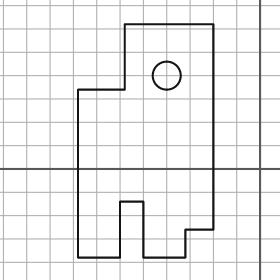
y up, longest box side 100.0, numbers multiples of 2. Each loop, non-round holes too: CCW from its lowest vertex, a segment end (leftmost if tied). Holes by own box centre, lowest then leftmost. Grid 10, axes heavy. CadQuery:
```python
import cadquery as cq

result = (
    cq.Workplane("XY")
    .moveTo(-78.0, -38.0)
    .lineTo(-60.0, -38.0)
    .lineTo(-60.0, -14.0)
    .lineTo(-50.0, -14.0)
    .lineTo(-50.0, -38.0)
    .lineTo(-32.0, -38.0)
    .lineTo(-32.0, -26.0)
    .lineTo(-20.0, -26.0)
    .lineTo(-20.0, 62.0)
    .lineTo(-58.0, 62.0)
    .lineTo(-58.0, 34.0)
    .lineTo(-78.0, 34.0)
    .close()
    .moveTo(-40.0, 40.0)
    .circle(6.0)
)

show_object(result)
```